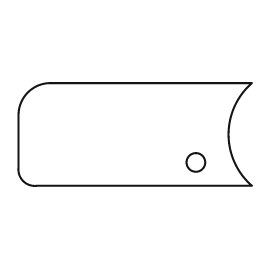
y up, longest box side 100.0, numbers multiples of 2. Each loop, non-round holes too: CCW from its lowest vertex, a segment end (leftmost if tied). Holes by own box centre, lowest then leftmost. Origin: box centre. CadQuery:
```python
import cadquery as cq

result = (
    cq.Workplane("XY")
    .moveTo(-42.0, -22.0)
    .lineTo(50.0, -22.0)
    .threePointArc((40.0, 0.0), (50.0, 22.0))
    .lineTo(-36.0, 22.0)
    .threePointArc((-46.0, 18.0), (-50.0, 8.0))
    .lineTo(-50.0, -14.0)
    .threePointArc((-48.0, -20.0), (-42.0, -22.0))
    .close()
    .moveTo(26.0, -12.0)
    .circle(4.0)
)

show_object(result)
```